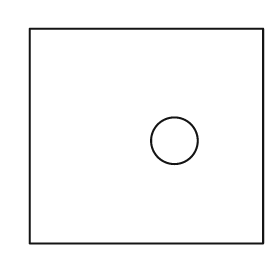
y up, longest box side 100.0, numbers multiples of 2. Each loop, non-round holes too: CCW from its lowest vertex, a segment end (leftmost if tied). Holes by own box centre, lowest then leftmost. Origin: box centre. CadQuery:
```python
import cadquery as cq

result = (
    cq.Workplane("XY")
    .moveTo(-50.0, -46.0)
    .lineTo(50.0, -46.0)
    .lineTo(50.0, 46.0)
    .lineTo(-50.0, 46.0)
    .close()
    .moveTo(12.0, -2.0)
    .circle(10.0)
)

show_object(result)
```